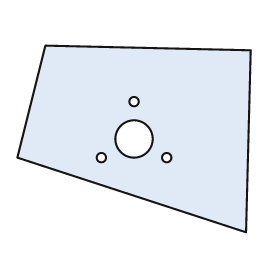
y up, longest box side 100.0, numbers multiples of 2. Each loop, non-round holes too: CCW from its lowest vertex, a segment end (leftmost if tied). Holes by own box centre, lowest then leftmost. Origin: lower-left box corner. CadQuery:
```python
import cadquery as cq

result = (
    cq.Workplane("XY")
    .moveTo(98.0, 0.0)
    .lineTo(100.0, 78.0)
    .lineTo(12.0, 80.0)
    .lineTo(0.0, 32.0)
    .close()
    .moveTo(36.0, 32.0)
    .circle(2.0)
    .moveTo(64.0, 32.0)
    .circle(2.0)
    .moveTo(50.0, 40.0)
    .circle(8.0)
    .moveTo(50.0, 56.0)
    .circle(2.0)
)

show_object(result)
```